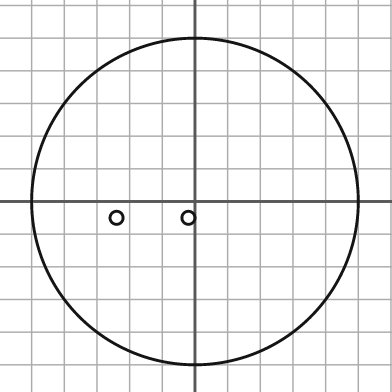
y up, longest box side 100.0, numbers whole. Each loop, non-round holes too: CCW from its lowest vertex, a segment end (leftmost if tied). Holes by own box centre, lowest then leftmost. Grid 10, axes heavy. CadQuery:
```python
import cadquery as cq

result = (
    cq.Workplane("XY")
    .moveTo(0.0, 0.0)
    .circle(50.0)
    .moveTo(-24.0, -5.0)
    .circle(2.0)
    .moveTo(-2.0, -5.0)
    .circle(2.0)
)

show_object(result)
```